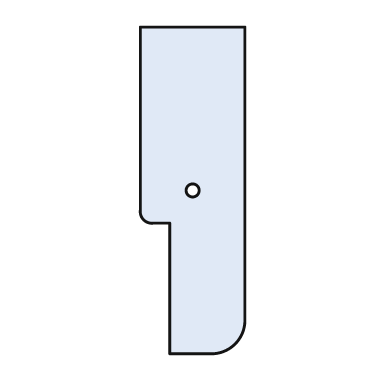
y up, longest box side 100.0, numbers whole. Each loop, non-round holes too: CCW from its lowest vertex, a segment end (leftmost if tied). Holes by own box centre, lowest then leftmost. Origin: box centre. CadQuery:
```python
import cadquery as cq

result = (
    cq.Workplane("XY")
    .moveTo(-7.0, -50.0)
    .lineTo(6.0, -50.0)
    .threePointArc((13.0, -47.0), (16.0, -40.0))
    .lineTo(16.0, 50.0)
    .lineTo(-16.0, 50.0)
    .lineTo(-16.0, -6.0)
    .threePointArc((-15.0, -9.0), (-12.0, -10.0))
    .lineTo(-7.0, -10.0)
    .close()
    .moveTo(0.0, 0.0)
    .circle(2.0)
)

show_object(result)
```